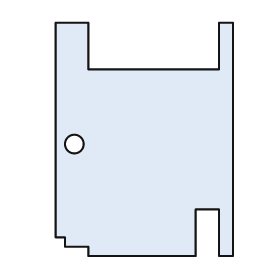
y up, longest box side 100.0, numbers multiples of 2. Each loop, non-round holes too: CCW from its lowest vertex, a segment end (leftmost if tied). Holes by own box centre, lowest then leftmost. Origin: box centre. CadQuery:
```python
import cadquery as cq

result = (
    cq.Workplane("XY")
    .moveTo(-24.0, -50.0)
    .lineTo(22.0, -50.0)
    .lineTo(22.0, -30.0)
    .lineTo(32.0, -30.0)
    .lineTo(32.0, -50.0)
    .lineTo(38.0, -50.0)
    .lineTo(38.0, 50.0)
    .lineTo(32.0, 50.0)
    .lineTo(32.0, 30.0)
    .lineTo(-24.0, 30.0)
    .lineTo(-24.0, 50.0)
    .lineTo(-38.0, 50.0)
    .lineTo(-38.0, -42.0)
    .lineTo(-34.0, -42.0)
    .lineTo(-34.0, -46.0)
    .lineTo(-24.0, -46.0)
    .close()
    .moveTo(-30.0, -2.0)
    .circle(4.0)
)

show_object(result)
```